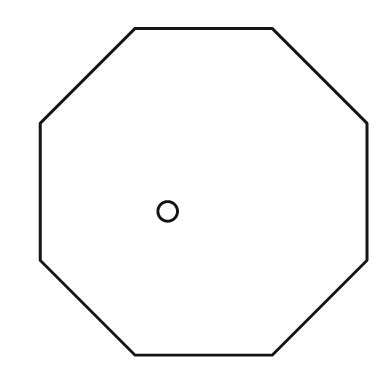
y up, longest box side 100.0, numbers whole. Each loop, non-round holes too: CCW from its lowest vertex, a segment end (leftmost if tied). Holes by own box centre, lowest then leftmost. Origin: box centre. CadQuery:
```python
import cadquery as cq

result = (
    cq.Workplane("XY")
    .moveTo(-21.0, -50.0)
    .lineTo(21.0, -50.0)
    .lineTo(50.0, -21.0)
    .lineTo(50.0, 21.0)
    .lineTo(21.0, 50.0)
    .lineTo(-21.0, 50.0)
    .lineTo(-50.0, 21.0)
    .lineTo(-50.0, -21.0)
    .close()
    .moveTo(-11.0, -6.0)
    .circle(3.0)
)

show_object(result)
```